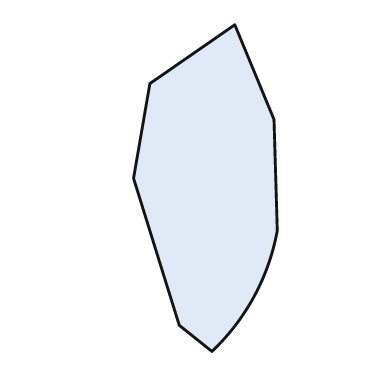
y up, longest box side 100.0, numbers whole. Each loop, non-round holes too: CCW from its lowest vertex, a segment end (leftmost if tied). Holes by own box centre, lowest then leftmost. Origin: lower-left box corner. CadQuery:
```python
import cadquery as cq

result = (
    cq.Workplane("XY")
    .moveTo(24.0, 0.0)
    .threePointArc((37.0, 17.0), (44.0, 37.0))
    .lineTo(43.0, 71.0)
    .lineTo(31.0, 100.0)
    .lineTo(5.0, 82.0)
    .lineTo(0.0, 53.0)
    .lineTo(14.0, 8.0)
    .close()
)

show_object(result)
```